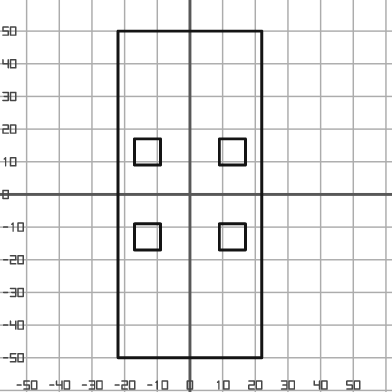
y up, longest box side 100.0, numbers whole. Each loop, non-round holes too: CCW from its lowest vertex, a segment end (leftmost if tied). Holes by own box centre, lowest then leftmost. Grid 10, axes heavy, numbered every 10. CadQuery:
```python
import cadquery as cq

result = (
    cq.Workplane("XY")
    .moveTo(-22.0, -50.0)
    .lineTo(22.0, -50.0)
    .lineTo(22.0, 50.0)
    .lineTo(-22.0, 50.0)
    .close()
    .moveTo(-17.0, -17.0)
    .lineTo(-9.0, -17.0)
    .lineTo(-9.0, -9.0)
    .lineTo(-17.0, -9.0)
    .close()
    .moveTo(9.0, -17.0)
    .lineTo(17.0, -17.0)
    .lineTo(17.0, -9.0)
    .lineTo(9.0, -9.0)
    .close()
    .moveTo(-17.0, 9.0)
    .lineTo(-9.0, 9.0)
    .lineTo(-9.0, 17.0)
    .lineTo(-17.0, 17.0)
    .close()
    .moveTo(9.0, 9.0)
    .lineTo(17.0, 9.0)
    .lineTo(17.0, 17.0)
    .lineTo(9.0, 17.0)
    .close()
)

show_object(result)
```